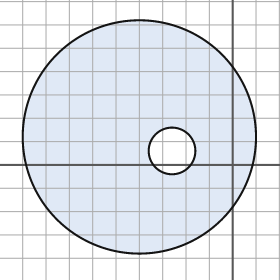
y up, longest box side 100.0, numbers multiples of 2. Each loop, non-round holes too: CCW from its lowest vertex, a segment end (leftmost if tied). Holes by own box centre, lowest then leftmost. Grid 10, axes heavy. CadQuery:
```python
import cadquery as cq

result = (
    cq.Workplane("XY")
    .moveTo(-40.0, 12.0)
    .circle(50.0)
    .moveTo(-26.0, 6.0)
    .circle(10.0)
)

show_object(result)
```